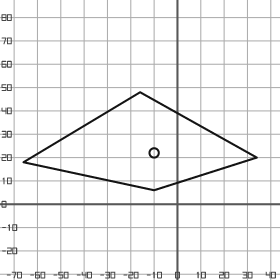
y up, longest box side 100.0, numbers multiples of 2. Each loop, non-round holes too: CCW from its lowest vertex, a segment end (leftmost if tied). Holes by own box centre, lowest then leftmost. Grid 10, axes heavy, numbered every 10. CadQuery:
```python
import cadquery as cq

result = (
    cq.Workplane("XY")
    .moveTo(-10.0, 6.0)
    .lineTo(34.0, 20.0)
    .lineTo(-16.0, 48.0)
    .lineTo(-66.0, 18.0)
    .close()
    .moveTo(-10.0, 22.0)
    .circle(2.0)
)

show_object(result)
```